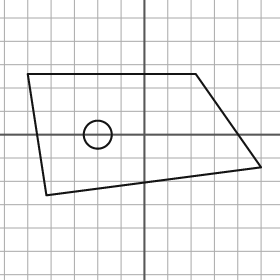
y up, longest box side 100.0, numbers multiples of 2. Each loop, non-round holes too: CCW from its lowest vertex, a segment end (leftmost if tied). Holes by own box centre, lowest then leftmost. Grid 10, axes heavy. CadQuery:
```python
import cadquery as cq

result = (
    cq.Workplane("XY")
    .moveTo(-42.0, -26.0)
    .lineTo(50.0, -14.0)
    .lineTo(22.0, 26.0)
    .lineTo(-50.0, 26.0)
    .close()
    .moveTo(-20.0, 0.0)
    .circle(6.0)
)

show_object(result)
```